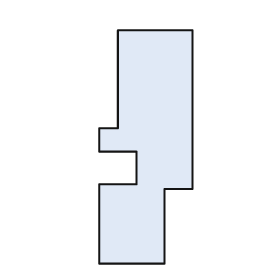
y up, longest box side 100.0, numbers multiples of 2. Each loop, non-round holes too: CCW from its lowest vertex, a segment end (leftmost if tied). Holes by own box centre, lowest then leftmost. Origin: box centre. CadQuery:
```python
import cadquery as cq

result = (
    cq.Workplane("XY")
    .moveTo(-20.0, -50.0)
    .lineTo(8.0, -50.0)
    .lineTo(8.0, -18.0)
    .lineTo(20.0, -18.0)
    .lineTo(20.0, 50.0)
    .lineTo(-12.0, 50.0)
    .lineTo(-12.0, 8.0)
    .lineTo(-20.0, 8.0)
    .lineTo(-20.0, -2.0)
    .lineTo(-4.0, -2.0)
    .lineTo(-4.0, -16.0)
    .lineTo(-20.0, -16.0)
    .close()
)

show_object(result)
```